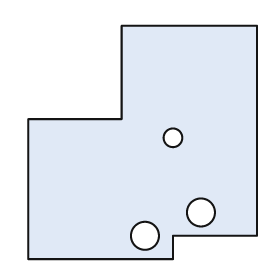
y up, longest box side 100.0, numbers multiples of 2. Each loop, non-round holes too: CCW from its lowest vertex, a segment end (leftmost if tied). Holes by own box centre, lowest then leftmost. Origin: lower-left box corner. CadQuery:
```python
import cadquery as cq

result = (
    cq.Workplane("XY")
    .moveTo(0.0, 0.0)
    .lineTo(62.0, 0.0)
    .lineTo(62.0, 10.0)
    .lineTo(98.0, 10.0)
    .lineTo(98.0, 100.0)
    .lineTo(40.0, 100.0)
    .lineTo(40.0, 60.0)
    .lineTo(0.0, 60.0)
    .close()
    .moveTo(50.0, 10.0)
    .circle(6.0)
    .moveTo(74.0, 20.0)
    .circle(6.0)
    .moveTo(62.0, 52.0)
    .circle(4.0)
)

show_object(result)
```